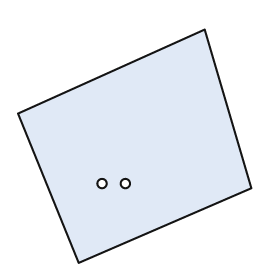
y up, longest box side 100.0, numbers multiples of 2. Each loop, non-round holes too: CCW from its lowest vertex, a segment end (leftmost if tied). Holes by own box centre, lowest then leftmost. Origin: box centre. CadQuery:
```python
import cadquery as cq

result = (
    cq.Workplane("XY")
    .moveTo(-24.0, -50.0)
    .lineTo(50.0, -18.0)
    .lineTo(30.0, 50.0)
    .lineTo(-50.0, 14.0)
    .close()
    .moveTo(-14.0, -16.0)
    .circle(2.0)
    .moveTo(-4.0, -16.0)
    .circle(2.0)
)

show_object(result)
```